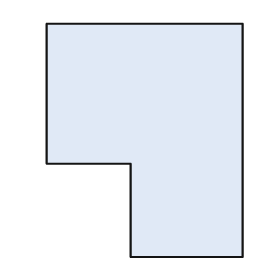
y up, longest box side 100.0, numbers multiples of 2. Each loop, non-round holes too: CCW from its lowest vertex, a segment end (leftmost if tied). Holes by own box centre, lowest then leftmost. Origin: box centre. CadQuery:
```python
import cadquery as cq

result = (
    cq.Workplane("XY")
    .moveTo(-6.0, -50.0)
    .lineTo(42.0, -50.0)
    .lineTo(42.0, 50.0)
    .lineTo(-42.0, 50.0)
    .lineTo(-42.0, -10.0)
    .lineTo(-6.0, -10.0)
    .close()
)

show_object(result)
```